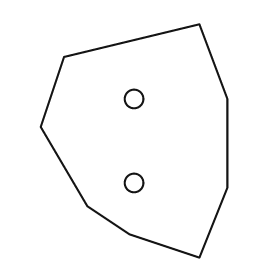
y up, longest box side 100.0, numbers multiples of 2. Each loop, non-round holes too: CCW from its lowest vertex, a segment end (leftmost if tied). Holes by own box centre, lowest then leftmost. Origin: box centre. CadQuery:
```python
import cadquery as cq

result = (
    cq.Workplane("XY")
    .moveTo(28.0, -50.0)
    .lineTo(40.0, -20.0)
    .lineTo(40.0, 18.0)
    .lineTo(28.0, 50.0)
    .lineTo(-30.0, 36.0)
    .lineTo(-40.0, 6.0)
    .lineTo(-20.0, -28.0)
    .lineTo(-2.0, -40.0)
    .close()
    .moveTo(0.0, -18.0)
    .circle(4.0)
    .moveTo(0.0, 18.0)
    .circle(4.0)
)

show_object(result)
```